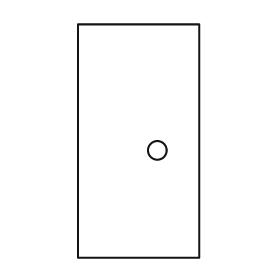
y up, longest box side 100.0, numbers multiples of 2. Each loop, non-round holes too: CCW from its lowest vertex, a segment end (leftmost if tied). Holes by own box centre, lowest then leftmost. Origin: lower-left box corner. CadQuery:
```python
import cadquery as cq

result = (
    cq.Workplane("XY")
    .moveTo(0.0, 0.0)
    .lineTo(52.0, 0.0)
    .lineTo(52.0, 100.0)
    .lineTo(0.0, 100.0)
    .close()
    .moveTo(34.0, 46.0)
    .circle(4.0)
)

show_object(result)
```